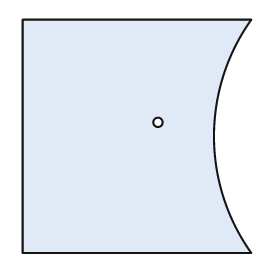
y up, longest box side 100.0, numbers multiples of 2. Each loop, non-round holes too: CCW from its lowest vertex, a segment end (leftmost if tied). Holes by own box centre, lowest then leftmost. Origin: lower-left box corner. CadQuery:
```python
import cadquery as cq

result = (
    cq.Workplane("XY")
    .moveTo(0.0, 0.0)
    .lineTo(98.0, 0.0)
    .threePointArc((82.0, 50.0), (98.0, 100.0))
    .lineTo(0.0, 100.0)
    .close()
    .moveTo(58.0, 56.0)
    .circle(2.0)
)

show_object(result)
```